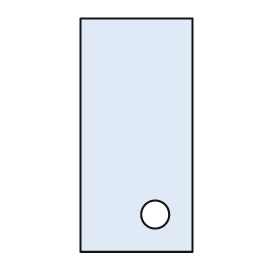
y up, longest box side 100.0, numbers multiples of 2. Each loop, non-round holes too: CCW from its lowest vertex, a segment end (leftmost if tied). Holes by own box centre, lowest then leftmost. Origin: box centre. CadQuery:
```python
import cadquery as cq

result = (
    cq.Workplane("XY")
    .moveTo(-24.0, -50.0)
    .lineTo(24.0, -50.0)
    .lineTo(24.0, 50.0)
    .lineTo(-24.0, 50.0)
    .close()
    .moveTo(8.0, -34.0)
    .circle(6.0)
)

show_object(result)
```